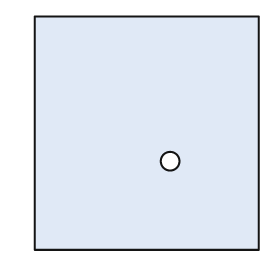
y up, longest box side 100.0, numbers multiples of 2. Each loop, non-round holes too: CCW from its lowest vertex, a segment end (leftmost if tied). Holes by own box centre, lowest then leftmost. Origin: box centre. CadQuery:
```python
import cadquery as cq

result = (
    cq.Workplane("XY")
    .moveTo(-48.0, -50.0)
    .lineTo(48.0, -50.0)
    .lineTo(48.0, 50.0)
    .lineTo(-48.0, 50.0)
    .close()
    .moveTo(10.0, -12.0)
    .circle(4.0)
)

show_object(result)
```